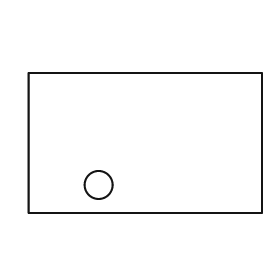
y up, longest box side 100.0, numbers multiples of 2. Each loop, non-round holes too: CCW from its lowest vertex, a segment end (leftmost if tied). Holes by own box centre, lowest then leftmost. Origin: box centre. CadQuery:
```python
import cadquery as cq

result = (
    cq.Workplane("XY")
    .moveTo(-50.0, -30.0)
    .lineTo(50.0, -30.0)
    .lineTo(50.0, 30.0)
    .lineTo(-50.0, 30.0)
    .close()
    .moveTo(-20.0, -18.0)
    .circle(6.0)
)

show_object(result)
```